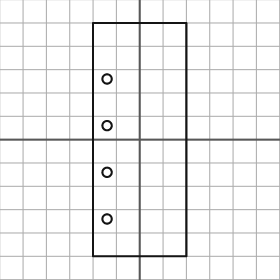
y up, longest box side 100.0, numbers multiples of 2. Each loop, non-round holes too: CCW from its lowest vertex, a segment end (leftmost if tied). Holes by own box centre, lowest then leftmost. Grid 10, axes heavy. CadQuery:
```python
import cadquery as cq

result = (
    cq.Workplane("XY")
    .moveTo(-20.0, -50.0)
    .lineTo(20.0, -50.0)
    .lineTo(20.0, 50.0)
    .lineTo(-20.0, 50.0)
    .close()
    .moveTo(-14.0, -34.0)
    .circle(2.0)
    .moveTo(-14.0, -14.0)
    .circle(2.0)
    .moveTo(-14.0, 6.0)
    .circle(2.0)
    .moveTo(-14.0, 26.0)
    .circle(2.0)
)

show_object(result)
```